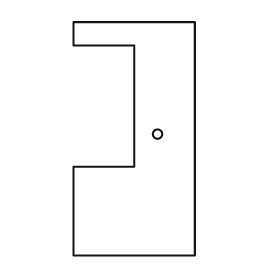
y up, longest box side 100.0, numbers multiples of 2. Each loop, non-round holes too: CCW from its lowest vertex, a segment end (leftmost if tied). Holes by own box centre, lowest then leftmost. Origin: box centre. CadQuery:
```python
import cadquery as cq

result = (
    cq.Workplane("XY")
    .moveTo(-26.0, -50.0)
    .lineTo(26.0, -50.0)
    .lineTo(26.0, 50.0)
    .lineTo(-26.0, 50.0)
    .lineTo(-26.0, 40.0)
    .lineTo(0.0, 40.0)
    .lineTo(0.0, -12.0)
    .lineTo(-26.0, -12.0)
    .close()
    .moveTo(10.0, 2.0)
    .circle(2.0)
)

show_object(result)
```